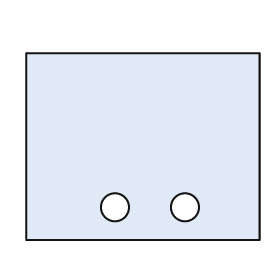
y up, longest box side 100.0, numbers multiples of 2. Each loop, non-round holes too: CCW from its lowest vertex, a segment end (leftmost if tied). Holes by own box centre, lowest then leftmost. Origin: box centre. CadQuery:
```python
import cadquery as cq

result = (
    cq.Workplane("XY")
    .moveTo(-50.0, -40.0)
    .lineTo(50.0, -40.0)
    .lineTo(50.0, 40.0)
    .lineTo(-50.0, 40.0)
    .close()
    .moveTo(-12.0, -26.0)
    .circle(6.0)
    .moveTo(18.0, -26.0)
    .circle(6.0)
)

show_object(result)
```